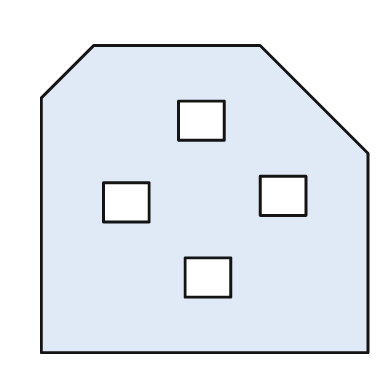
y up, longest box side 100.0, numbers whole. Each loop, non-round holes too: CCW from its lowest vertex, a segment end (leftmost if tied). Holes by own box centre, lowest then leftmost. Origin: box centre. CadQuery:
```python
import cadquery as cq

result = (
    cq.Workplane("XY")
    .moveTo(-50.0, -47.0)
    .lineTo(50.0, -47.0)
    .lineTo(50.0, 14.0)
    .lineTo(17.0, 47.0)
    .lineTo(-34.0, 47.0)
    .lineTo(-50.0, 31.0)
    .close()
    .moveTo(-6.0, -30.0)
    .lineTo(8.0, -30.0)
    .lineTo(8.0, -18.0)
    .lineTo(-6.0, -18.0)
    .close()
    .moveTo(-31.0, -7.0)
    .lineTo(-17.0, -7.0)
    .lineTo(-17.0, 5.0)
    .lineTo(-31.0, 5.0)
    .close()
    .moveTo(17.0, -5.0)
    .lineTo(31.0, -5.0)
    .lineTo(31.0, 7.0)
    .lineTo(17.0, 7.0)
    .close()
    .moveTo(-8.0, 18.0)
    .lineTo(6.0, 18.0)
    .lineTo(6.0, 30.0)
    .lineTo(-8.0, 30.0)
    .close()
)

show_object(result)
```